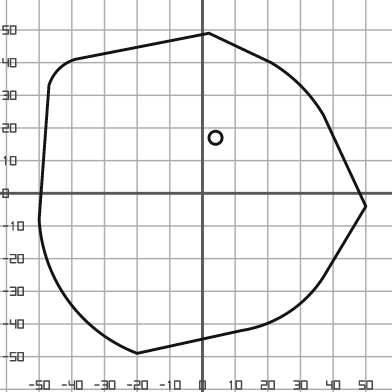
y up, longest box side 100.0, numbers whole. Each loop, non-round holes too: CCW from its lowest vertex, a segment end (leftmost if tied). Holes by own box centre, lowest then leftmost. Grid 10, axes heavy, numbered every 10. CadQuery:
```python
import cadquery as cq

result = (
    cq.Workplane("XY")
    .moveTo(-20.0, -49.0)
    .lineTo(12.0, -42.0)
    .threePointArc((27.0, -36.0), (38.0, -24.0))
    .lineTo(50.0, -4.0)
    .lineTo(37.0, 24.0)
    .threePointArc((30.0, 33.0), (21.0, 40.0))
    .lineTo(2.0, 49.0)
    .lineTo(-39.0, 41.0)
    .threePointArc((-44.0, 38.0), (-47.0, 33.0))
    .lineTo(-50.0, -8.0)
    .threePointArc((-41.0, -33.0), (-20.0, -49.0))
    .close()
    .moveTo(4.0, 17.0)
    .circle(2.0)
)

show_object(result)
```